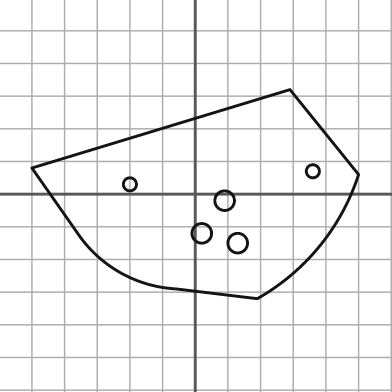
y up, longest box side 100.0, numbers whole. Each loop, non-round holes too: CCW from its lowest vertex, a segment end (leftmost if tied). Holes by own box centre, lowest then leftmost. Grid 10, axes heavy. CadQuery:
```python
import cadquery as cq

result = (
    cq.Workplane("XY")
    .moveTo(19.0, -32.0)
    .threePointArc((38.0, -16.0), (50.0, 6.0))
    .lineTo(29.0, 32.0)
    .lineTo(-50.0, 8.0)
    .lineTo(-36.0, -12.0)
    .threePointArc((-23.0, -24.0), (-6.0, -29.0))
    .close()
    .moveTo(13.0, -15.0)
    .circle(3.0)
    .moveTo(2.0, -12.0)
    .circle(3.0)
    .moveTo(9.0, -2.0)
    .circle(3.0)
    .moveTo(-20.0, 3.0)
    .circle(2.0)
    .moveTo(36.0, 7.0)
    .circle(2.0)
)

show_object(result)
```